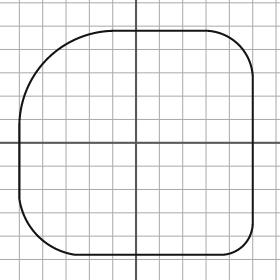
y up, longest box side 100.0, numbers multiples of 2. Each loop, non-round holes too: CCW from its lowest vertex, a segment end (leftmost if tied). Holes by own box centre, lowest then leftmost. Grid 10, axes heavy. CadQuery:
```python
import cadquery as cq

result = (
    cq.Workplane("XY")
    .moveTo(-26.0, -48.0)
    .lineTo(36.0, -48.0)
    .threePointArc((46.0, -44.0), (50.0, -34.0))
    .lineTo(50.0, 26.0)
    .threePointArc((44.0, 42.0), (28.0, 48.0))
    .lineTo(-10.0, 48.0)
    .threePointArc((-38.0, 36.0), (-50.0, 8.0))
    .lineTo(-50.0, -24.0)
    .threePointArc((-42.0, -40.0), (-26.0, -48.0))
    .close()
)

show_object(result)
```